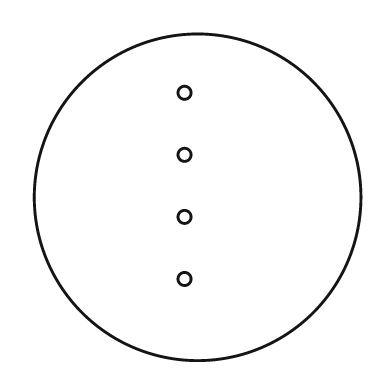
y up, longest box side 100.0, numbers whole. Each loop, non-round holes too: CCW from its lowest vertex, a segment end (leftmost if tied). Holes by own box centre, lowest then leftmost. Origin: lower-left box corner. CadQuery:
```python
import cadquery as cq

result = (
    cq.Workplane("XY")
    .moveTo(50.0, 50.0)
    .circle(50.0)
    .moveTo(46.0, 25.0)
    .circle(2.0)
    .moveTo(46.0, 44.0)
    .circle(2.0)
    .moveTo(46.0, 63.0)
    .circle(2.0)
    .moveTo(46.0, 82.0)
    .circle(2.0)
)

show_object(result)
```